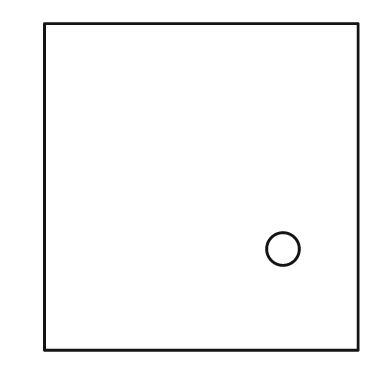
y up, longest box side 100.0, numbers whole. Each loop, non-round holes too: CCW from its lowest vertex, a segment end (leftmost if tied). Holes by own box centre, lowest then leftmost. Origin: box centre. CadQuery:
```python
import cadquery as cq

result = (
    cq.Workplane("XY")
    .moveTo(-48.0, -50.0)
    .lineTo(48.0, -50.0)
    .lineTo(48.0, 50.0)
    .lineTo(-48.0, 50.0)
    .close()
    .moveTo(25.0, -19.0)
    .circle(5.0)
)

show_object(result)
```